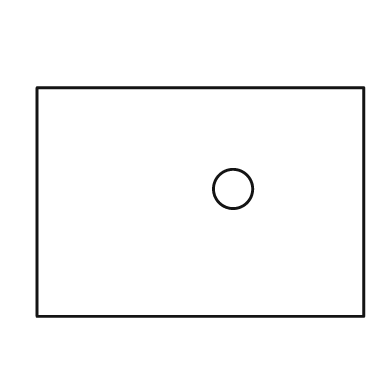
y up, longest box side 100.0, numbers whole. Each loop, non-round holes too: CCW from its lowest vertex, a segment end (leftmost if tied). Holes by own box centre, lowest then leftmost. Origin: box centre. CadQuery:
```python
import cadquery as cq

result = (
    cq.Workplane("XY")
    .moveTo(-50.0, -35.0)
    .lineTo(50.0, -35.0)
    .lineTo(50.0, 35.0)
    .lineTo(-50.0, 35.0)
    .close()
    .moveTo(10.0, 4.0)
    .circle(6.0)
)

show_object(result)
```